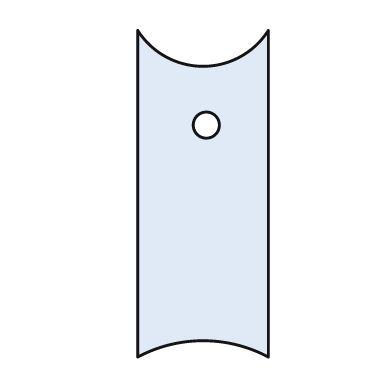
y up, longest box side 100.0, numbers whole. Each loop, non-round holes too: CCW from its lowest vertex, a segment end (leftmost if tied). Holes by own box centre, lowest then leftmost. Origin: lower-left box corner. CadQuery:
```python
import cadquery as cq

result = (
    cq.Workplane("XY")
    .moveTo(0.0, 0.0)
    .threePointArc((20.0, 5.0), (40.0, 0.0))
    .lineTo(40.0, 100.0)
    .threePointArc((20.0, 89.0), (0.0, 100.0))
    .close()
    .moveTo(21.0, 71.0)
    .circle(4.0)
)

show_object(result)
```